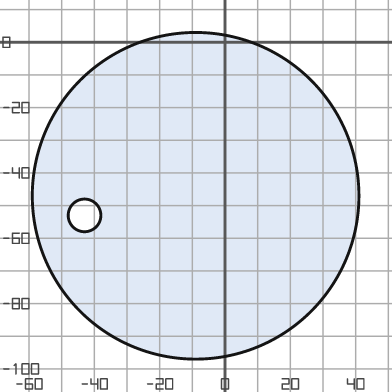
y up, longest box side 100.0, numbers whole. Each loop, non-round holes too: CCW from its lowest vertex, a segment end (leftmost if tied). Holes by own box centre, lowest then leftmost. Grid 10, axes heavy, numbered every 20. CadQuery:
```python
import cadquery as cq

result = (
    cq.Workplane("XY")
    .moveTo(-9.0, -47.0)
    .circle(50.0)
    .moveTo(-43.0, -53.0)
    .circle(5.0)
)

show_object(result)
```